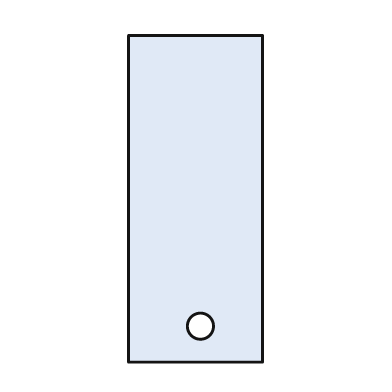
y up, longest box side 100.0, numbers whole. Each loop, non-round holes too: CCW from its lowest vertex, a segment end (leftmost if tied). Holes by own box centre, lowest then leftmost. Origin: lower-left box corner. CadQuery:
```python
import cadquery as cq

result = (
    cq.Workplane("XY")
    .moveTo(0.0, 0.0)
    .lineTo(41.0, 0.0)
    .lineTo(41.0, 100.0)
    .lineTo(0.0, 100.0)
    .close()
    .moveTo(22.0, 11.0)
    .circle(4.0)
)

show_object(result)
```